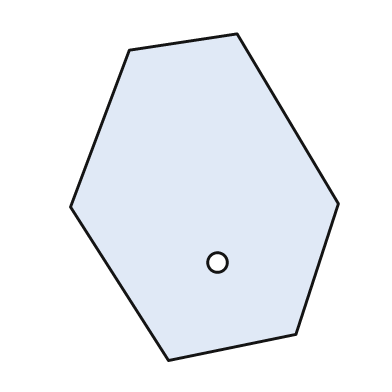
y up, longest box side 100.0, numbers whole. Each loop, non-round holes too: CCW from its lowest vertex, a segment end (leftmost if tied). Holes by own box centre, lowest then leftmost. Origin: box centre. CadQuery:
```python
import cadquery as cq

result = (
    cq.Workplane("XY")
    .moveTo(-11.0, -50.0)
    .lineTo(28.0, -42.0)
    .lineTo(41.0, -2.0)
    .lineTo(10.0, 50.0)
    .lineTo(-23.0, 45.0)
    .lineTo(-41.0, -3.0)
    .close()
    .moveTo(4.0, -20.0)
    .circle(3.0)
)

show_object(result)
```